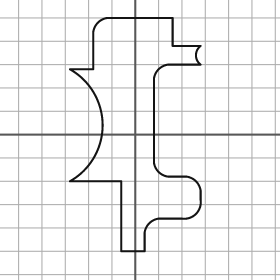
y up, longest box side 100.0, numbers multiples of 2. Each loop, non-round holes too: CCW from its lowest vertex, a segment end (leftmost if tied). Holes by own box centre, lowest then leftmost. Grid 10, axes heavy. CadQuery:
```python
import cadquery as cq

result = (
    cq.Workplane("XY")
    .moveTo(-6.0, -50.0)
    .lineTo(4.0, -50.0)
    .lineTo(4.0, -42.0)
    .threePointArc((6.0, -38.0), (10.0, -36.0))
    .lineTo(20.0, -36.0)
    .threePointArc((26.0, -34.0), (28.0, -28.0))
    .lineTo(28.0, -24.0)
    .threePointArc((26.0, -20.0), (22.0, -18.0))
    .lineTo(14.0, -18.0)
    .threePointArc((10.0, -16.0), (8.0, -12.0))
    .lineTo(8.0, 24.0)
    .threePointArc((10.0, 28.0), (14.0, 30.0))
    .lineTo(28.0, 30.0)
    .threePointArc((26.0, 34.0), (28.0, 38.0))
    .lineTo(16.0, 38.0)
    .lineTo(16.0, 50.0)
    .lineTo(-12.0, 50.0)
    .threePointArc((-16.0, 48.0), (-18.0, 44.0))
    .lineTo(-18.0, 28.0)
    .lineTo(-28.0, 28.0)
    .threePointArc((-14.0, 4.0), (-28.0, -20.0))
    .lineTo(-6.0, -20.0)
    .close()
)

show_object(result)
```